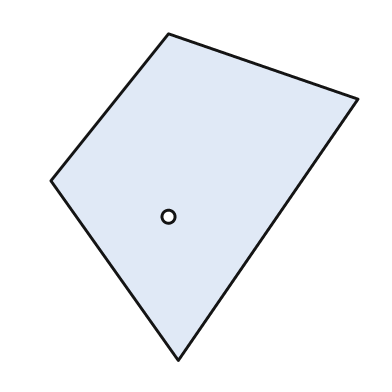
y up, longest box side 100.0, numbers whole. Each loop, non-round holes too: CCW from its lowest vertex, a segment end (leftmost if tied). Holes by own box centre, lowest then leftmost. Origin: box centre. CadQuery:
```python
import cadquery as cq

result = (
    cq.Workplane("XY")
    .moveTo(-8.0, -50.0)
    .lineTo(47.0, 30.0)
    .lineTo(-11.0, 50.0)
    .lineTo(-47.0, 5.0)
    .close()
    .moveTo(-11.0, -6.0)
    .circle(2.0)
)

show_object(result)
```